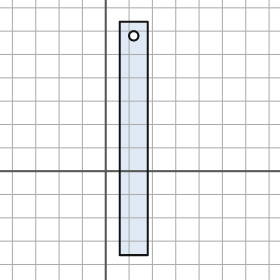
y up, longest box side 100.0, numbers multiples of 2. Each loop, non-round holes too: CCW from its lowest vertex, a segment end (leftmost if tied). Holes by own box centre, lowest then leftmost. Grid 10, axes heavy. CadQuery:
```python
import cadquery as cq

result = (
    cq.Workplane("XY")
    .moveTo(6.0, -36.0)
    .lineTo(18.0, -36.0)
    .lineTo(18.0, 64.0)
    .lineTo(6.0, 64.0)
    .close()
    .moveTo(12.0, 58.0)
    .circle(2.0)
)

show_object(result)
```